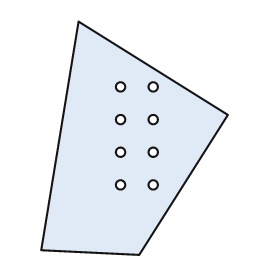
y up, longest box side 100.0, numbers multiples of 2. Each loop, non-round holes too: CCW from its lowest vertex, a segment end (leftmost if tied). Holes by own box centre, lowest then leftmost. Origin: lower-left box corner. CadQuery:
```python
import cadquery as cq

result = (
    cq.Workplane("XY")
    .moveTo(42.0, 0.0)
    .lineTo(80.0, 60.0)
    .lineTo(16.0, 100.0)
    .lineTo(0.0, 2.0)
    .close()
    .moveTo(34.0, 30.0)
    .circle(2.0)
    .moveTo(48.0, 30.0)
    .circle(2.0)
    .moveTo(34.0, 44.0)
    .circle(2.0)
    .moveTo(48.0, 44.0)
    .circle(2.0)
    .moveTo(34.0, 58.0)
    .circle(2.0)
    .moveTo(48.0, 58.0)
    .circle(2.0)
    .moveTo(34.0, 72.0)
    .circle(2.0)
    .moveTo(48.0, 72.0)
    .circle(2.0)
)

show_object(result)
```